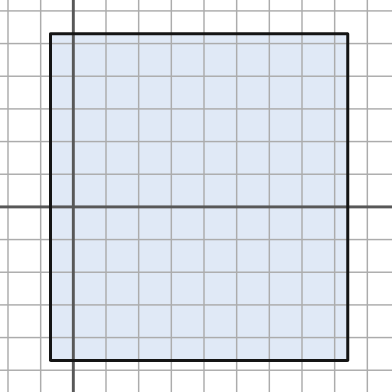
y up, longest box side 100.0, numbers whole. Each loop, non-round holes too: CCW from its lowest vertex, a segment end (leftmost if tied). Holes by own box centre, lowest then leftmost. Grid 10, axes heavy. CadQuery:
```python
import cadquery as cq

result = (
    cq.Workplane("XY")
    .moveTo(-7.0, -47.0)
    .lineTo(84.0, -47.0)
    .lineTo(84.0, 53.0)
    .lineTo(-7.0, 53.0)
    .close()
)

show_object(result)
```